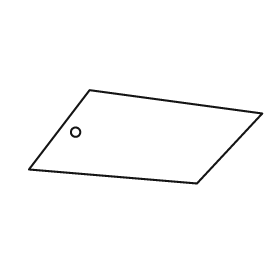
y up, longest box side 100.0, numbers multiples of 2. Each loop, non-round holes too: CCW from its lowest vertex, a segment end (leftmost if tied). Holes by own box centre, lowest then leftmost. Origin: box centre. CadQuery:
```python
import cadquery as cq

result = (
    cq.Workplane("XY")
    .moveTo(22.0, -20.0)
    .lineTo(50.0, 10.0)
    .lineTo(-24.0, 20.0)
    .lineTo(-50.0, -14.0)
    .close()
    .moveTo(-30.0, 2.0)
    .circle(2.0)
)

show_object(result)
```